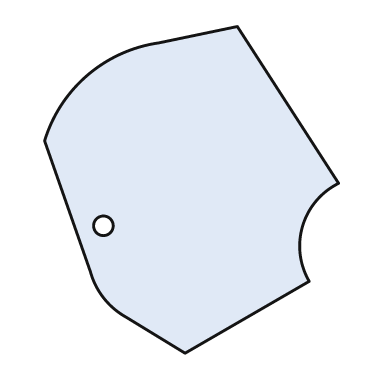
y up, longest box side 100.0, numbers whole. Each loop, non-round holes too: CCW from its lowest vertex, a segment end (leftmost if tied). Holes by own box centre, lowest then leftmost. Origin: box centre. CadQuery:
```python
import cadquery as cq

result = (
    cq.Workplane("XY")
    .moveTo(-2.0, -50.0)
    .lineTo(36.0, -28.0)
    .threePointArc((34.0, -11.0), (45.0, 2.0))
    .lineTo(14.0, 50.0)
    .lineTo(-10.0, 45.0)
    .threePointArc((-32.0, 35.0), (-45.0, 15.0))
    .lineTo(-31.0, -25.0)
    .threePointArc((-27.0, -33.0), (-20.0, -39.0))
    .close()
    .moveTo(-27.0, -11.0)
    .circle(3.0)
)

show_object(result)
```